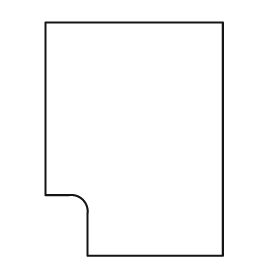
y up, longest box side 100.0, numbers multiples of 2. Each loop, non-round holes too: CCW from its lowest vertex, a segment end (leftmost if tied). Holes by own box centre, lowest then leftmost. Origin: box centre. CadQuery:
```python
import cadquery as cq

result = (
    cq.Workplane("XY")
    .moveTo(-20.0, -50.0)
    .lineTo(38.0, -50.0)
    .lineTo(38.0, 50.0)
    .lineTo(-38.0, 50.0)
    .lineTo(-38.0, -24.0)
    .lineTo(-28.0, -24.0)
    .threePointArc((-22.0, -26.0), (-20.0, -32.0))
    .close()
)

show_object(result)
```